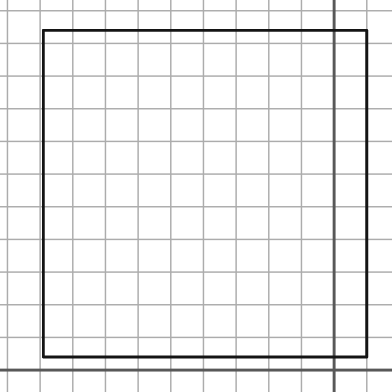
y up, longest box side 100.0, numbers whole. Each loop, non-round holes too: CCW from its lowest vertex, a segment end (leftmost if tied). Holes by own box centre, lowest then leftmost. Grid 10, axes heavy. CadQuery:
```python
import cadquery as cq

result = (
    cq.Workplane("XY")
    .moveTo(-89.0, 4.0)
    .lineTo(10.0, 4.0)
    .lineTo(10.0, 104.0)
    .lineTo(-89.0, 104.0)
    .close()
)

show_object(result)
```